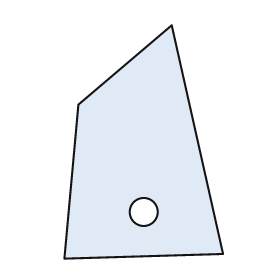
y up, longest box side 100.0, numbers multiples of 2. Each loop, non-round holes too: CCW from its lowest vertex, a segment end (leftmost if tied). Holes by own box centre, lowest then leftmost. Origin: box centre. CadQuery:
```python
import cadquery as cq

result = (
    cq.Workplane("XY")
    .moveTo(-34.0, -50.0)
    .lineTo(34.0, -48.0)
    .lineTo(12.0, 50.0)
    .lineTo(-28.0, 16.0)
    .close()
    .moveTo(0.0, -30.0)
    .circle(6.0)
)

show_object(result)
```